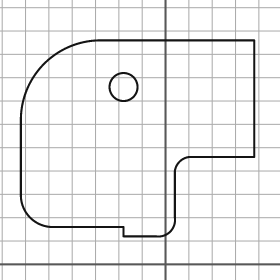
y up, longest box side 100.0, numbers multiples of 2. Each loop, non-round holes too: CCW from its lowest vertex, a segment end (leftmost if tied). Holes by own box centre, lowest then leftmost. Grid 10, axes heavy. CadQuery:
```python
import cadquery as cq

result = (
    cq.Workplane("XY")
    .moveTo(-18.0, 12.0)
    .lineTo(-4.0, 12.0)
    .threePointArc((2.0, 14.0), (4.0, 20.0))
    .lineTo(4.0, 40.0)
    .threePointArc((6.0, 44.0), (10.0, 46.0))
    .lineTo(38.0, 46.0)
    .lineTo(38.0, 96.0)
    .lineTo(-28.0, 96.0)
    .threePointArc((-52.0, 86.0), (-62.0, 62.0))
    .lineTo(-62.0, 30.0)
    .threePointArc((-58.0, 20.0), (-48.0, 16.0))
    .lineTo(-18.0, 16.0)
    .close()
    .moveTo(-18.0, 76.0)
    .circle(6.0)
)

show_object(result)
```